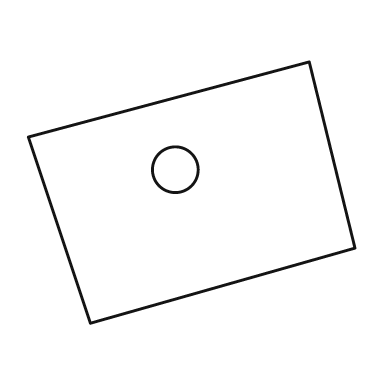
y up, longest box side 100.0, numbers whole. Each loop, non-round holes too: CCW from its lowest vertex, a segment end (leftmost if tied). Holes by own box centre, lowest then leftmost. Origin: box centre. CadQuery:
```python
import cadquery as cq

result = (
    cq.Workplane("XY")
    .moveTo(-31.0, -40.0)
    .lineTo(50.0, -17.0)
    .lineTo(36.0, 40.0)
    .lineTo(-50.0, 17.0)
    .close()
    .moveTo(-5.0, 7.0)
    .circle(7.0)
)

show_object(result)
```